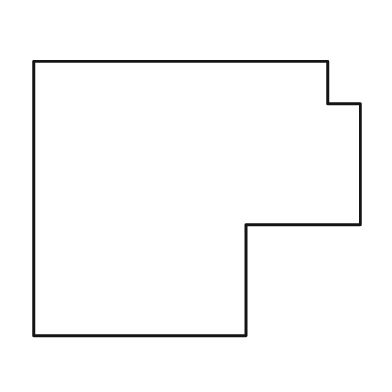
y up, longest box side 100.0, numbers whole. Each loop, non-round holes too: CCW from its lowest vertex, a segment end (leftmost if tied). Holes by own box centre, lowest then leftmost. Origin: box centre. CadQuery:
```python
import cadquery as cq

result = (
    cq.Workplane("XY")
    .moveTo(-50.0, -42.0)
    .lineTo(15.0, -42.0)
    .lineTo(15.0, -8.0)
    .lineTo(50.0, -8.0)
    .lineTo(50.0, 29.0)
    .lineTo(40.0, 29.0)
    .lineTo(40.0, 42.0)
    .lineTo(-50.0, 42.0)
    .close()
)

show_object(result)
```